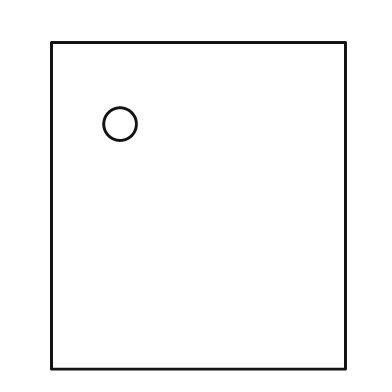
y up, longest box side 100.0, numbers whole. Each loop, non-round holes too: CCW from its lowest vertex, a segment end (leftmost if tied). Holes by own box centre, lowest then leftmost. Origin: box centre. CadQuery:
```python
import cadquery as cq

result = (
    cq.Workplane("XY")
    .moveTo(-45.0, -50.0)
    .lineTo(45.0, -50.0)
    .lineTo(45.0, 50.0)
    .lineTo(-45.0, 50.0)
    .close()
    .moveTo(-24.0, 25.0)
    .circle(5.0)
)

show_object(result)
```